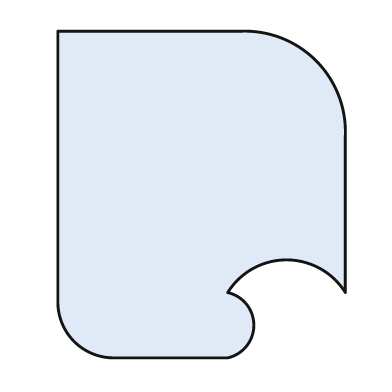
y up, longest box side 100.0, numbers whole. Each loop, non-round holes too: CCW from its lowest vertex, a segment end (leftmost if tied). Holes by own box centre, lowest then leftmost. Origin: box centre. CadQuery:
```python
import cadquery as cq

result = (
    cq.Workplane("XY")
    .moveTo(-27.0, -50.0)
    .lineTo(8.0, -50.0)
    .threePointArc((16.0, -40.0), (8.0, -30.0))
    .threePointArc((26.0, -20.0), (44.0, -30.0))
    .lineTo(44.0, 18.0)
    .threePointArc((35.0, 41.0), (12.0, 50.0))
    .lineTo(-44.0, 50.0)
    .lineTo(-44.0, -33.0)
    .threePointArc((-39.0, -45.0), (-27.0, -50.0))
    .close()
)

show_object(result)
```